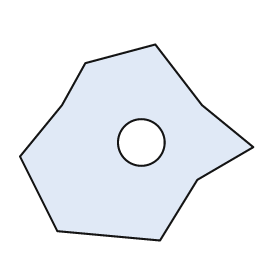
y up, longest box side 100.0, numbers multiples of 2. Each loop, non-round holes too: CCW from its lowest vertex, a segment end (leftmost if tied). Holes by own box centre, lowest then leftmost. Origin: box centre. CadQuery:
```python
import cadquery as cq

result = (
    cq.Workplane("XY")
    .moveTo(10.0, -42.0)
    .lineTo(26.0, -16.0)
    .lineTo(50.0, -2.0)
    .lineTo(28.0, 16.0)
    .lineTo(8.0, 42.0)
    .lineTo(-22.0, 34.0)
    .lineTo(-32.0, 16.0)
    .lineTo(-50.0, -6.0)
    .lineTo(-34.0, -38.0)
    .close()
    .moveTo(2.0, 0.0)
    .circle(10.0)
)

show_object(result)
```